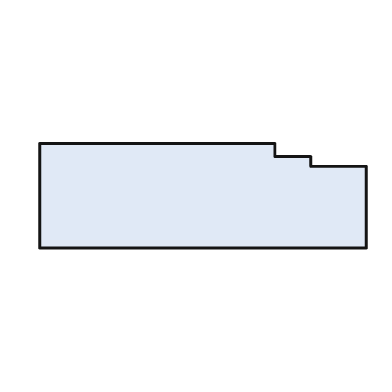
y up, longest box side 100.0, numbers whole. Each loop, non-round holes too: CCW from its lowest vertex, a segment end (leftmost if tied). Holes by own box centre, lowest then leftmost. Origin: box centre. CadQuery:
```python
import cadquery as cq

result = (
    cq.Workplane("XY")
    .moveTo(-50.0, -16.0)
    .lineTo(50.0, -16.0)
    .lineTo(50.0, 9.0)
    .lineTo(33.0, 9.0)
    .lineTo(33.0, 12.0)
    .lineTo(22.0, 12.0)
    .lineTo(22.0, 16.0)
    .lineTo(-50.0, 16.0)
    .close()
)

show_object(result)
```